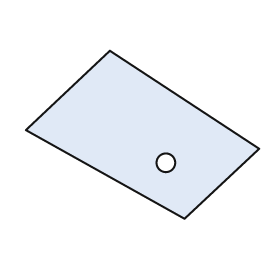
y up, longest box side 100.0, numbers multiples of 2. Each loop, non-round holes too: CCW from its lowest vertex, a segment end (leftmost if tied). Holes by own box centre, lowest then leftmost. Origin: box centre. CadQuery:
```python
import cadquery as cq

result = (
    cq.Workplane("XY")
    .moveTo(18.0, -36.0)
    .lineTo(50.0, -6.0)
    .lineTo(-14.0, 36.0)
    .lineTo(-50.0, 2.0)
    .close()
    .moveTo(10.0, -12.0)
    .circle(4.0)
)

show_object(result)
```